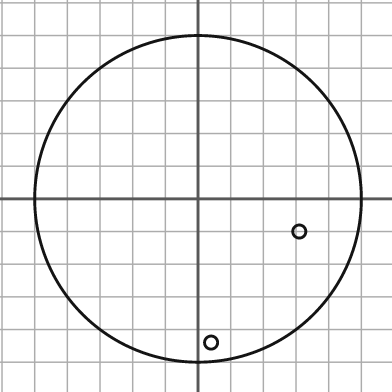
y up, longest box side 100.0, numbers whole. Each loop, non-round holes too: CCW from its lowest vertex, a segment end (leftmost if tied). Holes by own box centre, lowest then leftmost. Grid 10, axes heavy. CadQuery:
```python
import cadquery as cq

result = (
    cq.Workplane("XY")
    .moveTo(0.0, 0.0)
    .circle(50.0)
    .moveTo(4.0, -44.0)
    .circle(2.0)
    .moveTo(31.0, -10.0)
    .circle(2.0)
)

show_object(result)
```